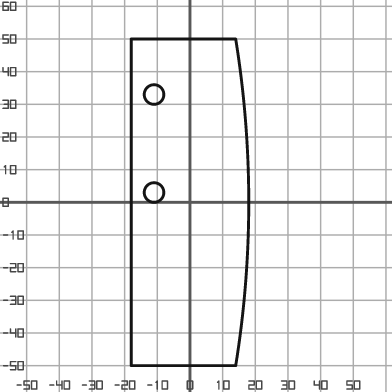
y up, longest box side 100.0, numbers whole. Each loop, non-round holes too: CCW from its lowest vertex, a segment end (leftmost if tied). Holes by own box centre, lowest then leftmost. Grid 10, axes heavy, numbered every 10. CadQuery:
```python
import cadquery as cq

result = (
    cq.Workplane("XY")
    .moveTo(-18.0, -50.0)
    .lineTo(14.0, -50.0)
    .threePointArc((18.0, 0.0), (14.0, 50.0))
    .lineTo(-18.0, 50.0)
    .close()
    .moveTo(-11.0, 3.0)
    .circle(3.0)
    .moveTo(-11.0, 33.0)
    .circle(3.0)
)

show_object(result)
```